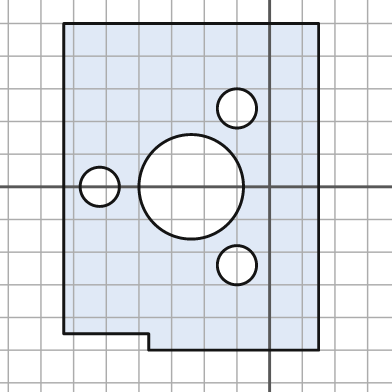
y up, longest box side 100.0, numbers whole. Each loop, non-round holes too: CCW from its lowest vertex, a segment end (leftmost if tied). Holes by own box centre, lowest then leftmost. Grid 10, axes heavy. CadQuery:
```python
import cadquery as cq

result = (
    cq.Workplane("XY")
    .moveTo(-37.0, -50.0)
    .lineTo(15.0, -50.0)
    .lineTo(15.0, 50.0)
    .lineTo(-63.0, 50.0)
    .lineTo(-63.0, -45.0)
    .lineTo(-37.0, -45.0)
    .close()
    .moveTo(-10.0, -24.0)
    .circle(6.0)
    .moveTo(-52.0, 0.0)
    .circle(6.0)
    .moveTo(-24.0, 0.0)
    .circle(16.0)
    .moveTo(-10.0, 24.0)
    .circle(6.0)
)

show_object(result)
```